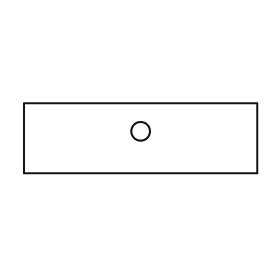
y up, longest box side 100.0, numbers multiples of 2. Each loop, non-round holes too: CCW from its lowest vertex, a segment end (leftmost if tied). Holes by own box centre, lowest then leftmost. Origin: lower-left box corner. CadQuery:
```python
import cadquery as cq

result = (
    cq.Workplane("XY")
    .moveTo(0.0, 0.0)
    .lineTo(100.0, 0.0)
    .lineTo(100.0, 30.0)
    .lineTo(0.0, 30.0)
    .close()
    .moveTo(50.0, 18.0)
    .circle(4.0)
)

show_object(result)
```